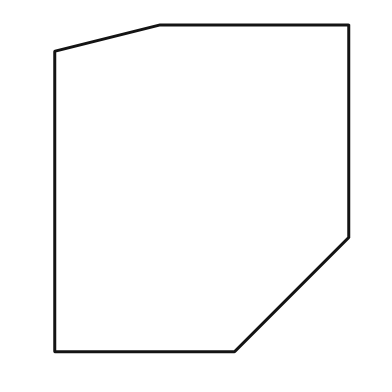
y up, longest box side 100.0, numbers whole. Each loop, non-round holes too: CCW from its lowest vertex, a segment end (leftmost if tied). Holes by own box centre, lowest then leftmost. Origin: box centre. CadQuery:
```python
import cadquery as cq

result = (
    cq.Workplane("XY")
    .moveTo(-45.0, -50.0)
    .lineTo(10.0, -50.0)
    .lineTo(45.0, -15.0)
    .lineTo(45.0, 50.0)
    .lineTo(-13.0, 50.0)
    .lineTo(-45.0, 42.0)
    .close()
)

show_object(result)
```